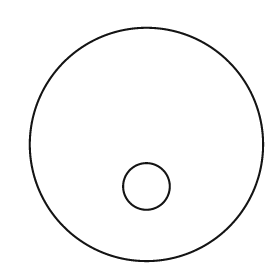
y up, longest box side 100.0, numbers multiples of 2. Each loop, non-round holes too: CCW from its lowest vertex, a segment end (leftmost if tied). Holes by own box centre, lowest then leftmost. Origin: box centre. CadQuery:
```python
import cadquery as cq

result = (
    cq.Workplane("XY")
    .moveTo(0.0, 0.0)
    .circle(50.0)
    .moveTo(0.0, -18.0)
    .circle(10.0)
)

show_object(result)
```